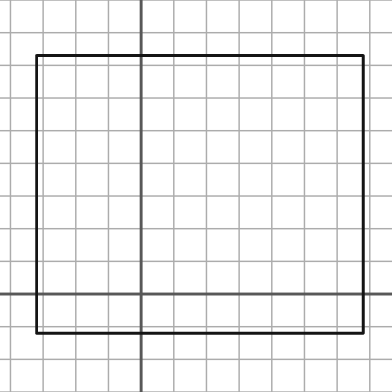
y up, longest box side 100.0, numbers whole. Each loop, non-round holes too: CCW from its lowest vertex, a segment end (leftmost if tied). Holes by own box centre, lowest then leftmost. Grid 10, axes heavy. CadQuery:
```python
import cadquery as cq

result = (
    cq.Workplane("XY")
    .moveTo(-32.0, -12.0)
    .lineTo(68.0, -12.0)
    .lineTo(68.0, 73.0)
    .lineTo(-32.0, 73.0)
    .close()
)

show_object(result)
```